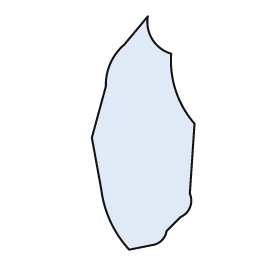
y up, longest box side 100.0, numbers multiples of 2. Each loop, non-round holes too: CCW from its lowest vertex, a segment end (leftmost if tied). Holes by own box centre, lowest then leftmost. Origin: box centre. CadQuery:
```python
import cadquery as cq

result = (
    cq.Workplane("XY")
    .moveTo(-6.0, -50.0)
    .lineTo(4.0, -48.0)
    .threePointArc((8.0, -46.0), (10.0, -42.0))
    .lineTo(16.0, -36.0)
    .threePointArc((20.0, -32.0), (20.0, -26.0))
    .lineTo(22.0, 4.0)
    .threePointArc((14.0, 18.0), (12.0, 34.0))
    .threePointArc((4.0, 40.0), (2.0, 50.0))
    .lineTo(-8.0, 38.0)
    .threePointArc((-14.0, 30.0), (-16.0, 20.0))
    .lineTo(-22.0, -2.0)
    .lineTo(-18.0, -24.0)
    .threePointArc((-14.0, -38.0), (-6.0, -50.0))
    .close()
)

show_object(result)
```